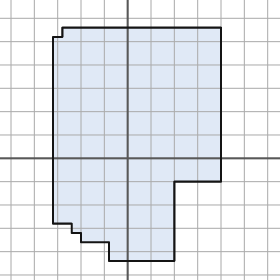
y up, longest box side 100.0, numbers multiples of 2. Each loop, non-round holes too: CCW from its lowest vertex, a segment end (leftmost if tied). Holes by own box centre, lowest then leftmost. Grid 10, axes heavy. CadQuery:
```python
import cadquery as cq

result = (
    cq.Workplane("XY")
    .moveTo(-8.0, -44.0)
    .lineTo(20.0, -44.0)
    .lineTo(20.0, -10.0)
    .lineTo(40.0, -10.0)
    .lineTo(40.0, 56.0)
    .lineTo(-28.0, 56.0)
    .lineTo(-28.0, 52.0)
    .lineTo(-32.0, 52.0)
    .lineTo(-32.0, -28.0)
    .lineTo(-24.0, -28.0)
    .lineTo(-24.0, -32.0)
    .lineTo(-20.0, -32.0)
    .lineTo(-20.0, -36.0)
    .lineTo(-8.0, -36.0)
    .close()
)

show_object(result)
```